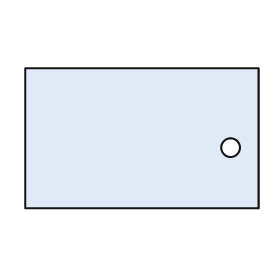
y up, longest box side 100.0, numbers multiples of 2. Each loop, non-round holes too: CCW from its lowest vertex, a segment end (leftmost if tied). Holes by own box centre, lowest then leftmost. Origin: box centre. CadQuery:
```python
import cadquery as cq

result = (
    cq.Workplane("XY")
    .moveTo(-50.0, -30.0)
    .lineTo(50.0, -30.0)
    .lineTo(50.0, 30.0)
    .lineTo(-50.0, 30.0)
    .close()
    .moveTo(38.0, -4.0)
    .circle(4.0)
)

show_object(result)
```